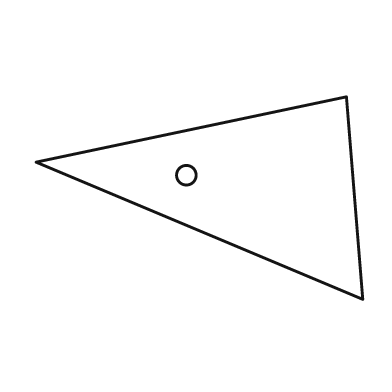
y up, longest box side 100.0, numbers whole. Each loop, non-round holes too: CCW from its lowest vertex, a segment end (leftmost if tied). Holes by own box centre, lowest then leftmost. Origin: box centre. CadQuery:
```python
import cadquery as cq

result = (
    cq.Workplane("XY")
    .moveTo(50.0, -31.0)
    .lineTo(45.0, 31.0)
    .lineTo(-50.0, 11.0)
    .close()
    .moveTo(-4.0, 7.0)
    .circle(3.0)
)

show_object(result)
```